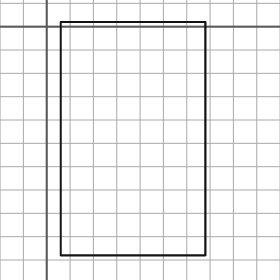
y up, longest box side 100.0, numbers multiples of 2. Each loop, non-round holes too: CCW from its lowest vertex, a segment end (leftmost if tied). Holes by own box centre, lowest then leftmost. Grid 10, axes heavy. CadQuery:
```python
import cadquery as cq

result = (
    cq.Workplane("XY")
    .moveTo(6.0, -98.0)
    .lineTo(68.0, -98.0)
    .lineTo(68.0, 2.0)
    .lineTo(6.0, 2.0)
    .close()
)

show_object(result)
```